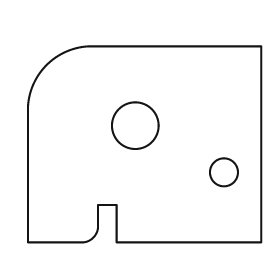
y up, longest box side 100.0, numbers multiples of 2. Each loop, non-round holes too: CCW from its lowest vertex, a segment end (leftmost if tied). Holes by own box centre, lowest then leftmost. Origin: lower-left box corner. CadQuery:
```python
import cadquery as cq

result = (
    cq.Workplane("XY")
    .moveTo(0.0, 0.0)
    .lineTo(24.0, 0.0)
    .threePointArc((28.0, 2.0), (30.0, 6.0))
    .lineTo(30.0, 16.0)
    .lineTo(38.0, 16.0)
    .lineTo(38.0, 0.0)
    .lineTo(100.0, 0.0)
    .lineTo(100.0, 84.0)
    .lineTo(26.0, 84.0)
    .threePointArc((8.0, 76.0), (0.0, 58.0))
    .close()
    .moveTo(84.0, 30.0)
    .circle(6.0)
    .moveTo(46.0, 50.0)
    .circle(10.0)
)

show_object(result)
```